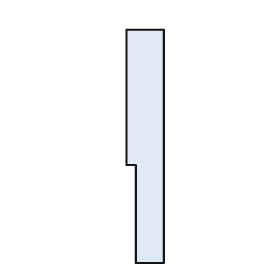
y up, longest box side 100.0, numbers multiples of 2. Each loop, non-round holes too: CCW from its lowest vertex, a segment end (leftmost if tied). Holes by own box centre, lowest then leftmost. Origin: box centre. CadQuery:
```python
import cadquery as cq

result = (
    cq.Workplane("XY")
    .moveTo(-4.0, -50.0)
    .lineTo(8.0, -50.0)
    .lineTo(8.0, 50.0)
    .lineTo(-8.0, 50.0)
    .lineTo(-8.0, -8.0)
    .lineTo(-4.0, -8.0)
    .close()
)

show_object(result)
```